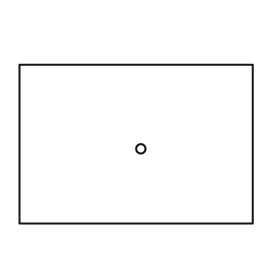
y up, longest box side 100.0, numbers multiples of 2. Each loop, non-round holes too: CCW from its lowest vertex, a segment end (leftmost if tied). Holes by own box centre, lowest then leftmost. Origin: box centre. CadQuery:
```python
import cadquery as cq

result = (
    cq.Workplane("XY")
    .moveTo(-50.0, -34.0)
    .lineTo(50.0, -34.0)
    .lineTo(50.0, 34.0)
    .lineTo(-50.0, 34.0)
    .close()
    .moveTo(2.0, -2.0)
    .circle(2.0)
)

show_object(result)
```